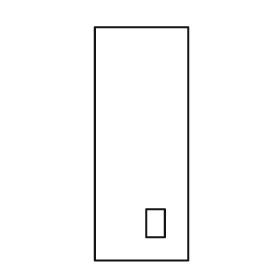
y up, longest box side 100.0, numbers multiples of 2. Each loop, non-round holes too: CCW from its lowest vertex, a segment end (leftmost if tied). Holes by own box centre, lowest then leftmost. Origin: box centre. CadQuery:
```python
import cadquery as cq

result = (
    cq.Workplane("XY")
    .moveTo(-20.0, -50.0)
    .lineTo(20.0, -50.0)
    .lineTo(20.0, 50.0)
    .lineTo(-20.0, 50.0)
    .close()
    .moveTo(2.0, -40.0)
    .lineTo(10.0, -40.0)
    .lineTo(10.0, -28.0)
    .lineTo(2.0, -28.0)
    .close()
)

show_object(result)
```